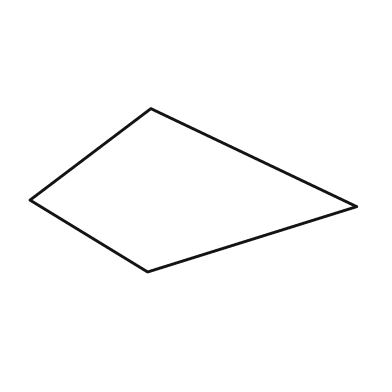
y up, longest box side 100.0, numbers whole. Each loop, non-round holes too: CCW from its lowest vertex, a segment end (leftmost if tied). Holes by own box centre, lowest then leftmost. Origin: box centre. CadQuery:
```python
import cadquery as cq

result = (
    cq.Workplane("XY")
    .moveTo(-14.0, -25.0)
    .lineTo(50.0, -5.0)
    .lineTo(-13.0, 25.0)
    .lineTo(-50.0, -3.0)
    .close()
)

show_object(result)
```